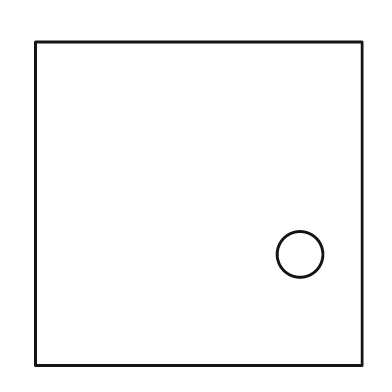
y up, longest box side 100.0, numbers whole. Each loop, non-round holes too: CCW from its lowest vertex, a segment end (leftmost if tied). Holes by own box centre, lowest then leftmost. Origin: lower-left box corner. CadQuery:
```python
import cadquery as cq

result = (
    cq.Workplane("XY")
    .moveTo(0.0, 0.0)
    .lineTo(100.0, 0.0)
    .lineTo(100.0, 99.0)
    .lineTo(0.0, 99.0)
    .close()
    .moveTo(81.0, 34.0)
    .circle(7.0)
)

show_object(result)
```